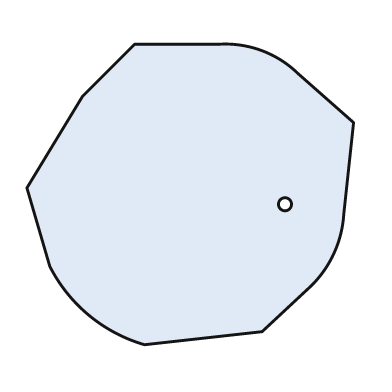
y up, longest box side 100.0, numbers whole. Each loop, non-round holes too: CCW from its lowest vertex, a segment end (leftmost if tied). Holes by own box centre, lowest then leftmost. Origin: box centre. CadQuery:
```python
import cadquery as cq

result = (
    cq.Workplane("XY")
    .moveTo(-14.0, -46.0)
    .lineTo(22.0, -42.0)
    .lineTo(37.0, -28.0)
    .threePointArc((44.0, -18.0), (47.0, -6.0))
    .lineTo(50.0, 22.0)
    .lineTo(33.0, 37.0)
    .threePointArc((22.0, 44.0), (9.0, 46.0))
    .lineTo(-17.0, 46.0)
    .lineTo(-33.0, 30.0)
    .lineTo(-50.0, 2.0)
    .lineTo(-43.0, -22.0)
    .threePointArc((-31.0, -37.0), (-14.0, -46.0))
    .close()
    .moveTo(29.0, -3.0)
    .circle(2.0)
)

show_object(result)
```